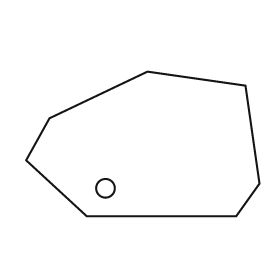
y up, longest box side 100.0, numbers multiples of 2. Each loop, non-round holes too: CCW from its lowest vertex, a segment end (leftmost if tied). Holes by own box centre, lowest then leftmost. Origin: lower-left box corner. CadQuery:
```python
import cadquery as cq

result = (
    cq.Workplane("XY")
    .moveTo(26.0, 0.0)
    .lineTo(90.0, 0.0)
    .lineTo(100.0, 14.0)
    .lineTo(94.0, 56.0)
    .lineTo(52.0, 62.0)
    .lineTo(10.0, 42.0)
    .lineTo(0.0, 24.0)
    .close()
    .moveTo(34.0, 12.0)
    .circle(4.0)
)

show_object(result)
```